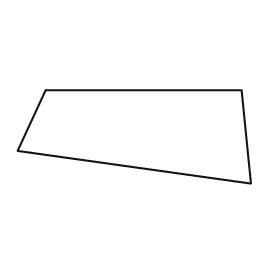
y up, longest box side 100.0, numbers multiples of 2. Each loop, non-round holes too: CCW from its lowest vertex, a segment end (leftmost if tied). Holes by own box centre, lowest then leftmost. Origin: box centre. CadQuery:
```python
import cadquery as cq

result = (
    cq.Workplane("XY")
    .moveTo(50.0, -20.0)
    .lineTo(46.0, 20.0)
    .lineTo(-38.0, 20.0)
    .lineTo(-50.0, -6.0)
    .close()
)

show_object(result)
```